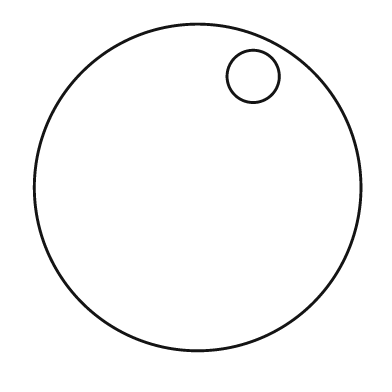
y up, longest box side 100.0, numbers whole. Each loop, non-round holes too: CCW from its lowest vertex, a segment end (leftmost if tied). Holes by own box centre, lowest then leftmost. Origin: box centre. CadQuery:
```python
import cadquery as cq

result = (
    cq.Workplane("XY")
    .moveTo(0.0, 0.0)
    .circle(50.0)
    .moveTo(17.0, 34.0)
    .circle(8.0)
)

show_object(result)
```